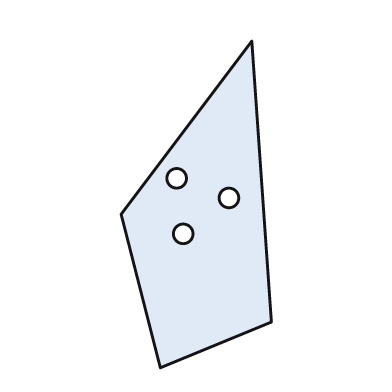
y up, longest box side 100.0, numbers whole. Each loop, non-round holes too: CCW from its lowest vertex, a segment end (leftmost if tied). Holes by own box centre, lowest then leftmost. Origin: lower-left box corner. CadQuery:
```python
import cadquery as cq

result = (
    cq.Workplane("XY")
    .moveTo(12.0, 0.0)
    .lineTo(46.0, 14.0)
    .lineTo(40.0, 100.0)
    .lineTo(0.0, 47.0)
    .close()
    .moveTo(19.0, 41.0)
    .circle(3.0)
    .moveTo(33.0, 52.0)
    .circle(3.0)
    .moveTo(17.0, 58.0)
    .circle(3.0)
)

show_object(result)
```